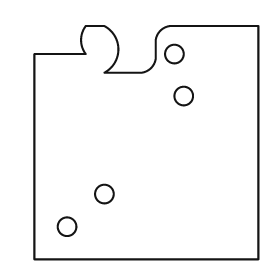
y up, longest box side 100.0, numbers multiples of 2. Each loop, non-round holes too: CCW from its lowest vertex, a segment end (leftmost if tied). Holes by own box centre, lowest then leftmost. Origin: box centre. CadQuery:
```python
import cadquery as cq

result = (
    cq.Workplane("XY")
    .moveTo(-48.0, -50.0)
    .lineTo(48.0, -50.0)
    .lineTo(48.0, 50.0)
    .lineTo(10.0, 50.0)
    .threePointArc((6.0, 48.0), (4.0, 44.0))
    .lineTo(4.0, 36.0)
    .threePointArc((2.0, 32.0), (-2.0, 30.0))
    .lineTo(-18.0, 30.0)
    .threePointArc((-12.0, 40.0), (-18.0, 50.0))
    .lineTo(-26.0, 50.0)
    .threePointArc((-28.0, 44.0), (-26.0, 38.0))
    .lineTo(-48.0, 38.0)
    .close()
    .moveTo(-34.0, -36.0)
    .circle(4.0)
    .moveTo(-18.0, -22.0)
    .circle(4.0)
    .moveTo(16.0, 20.0)
    .circle(4.0)
    .moveTo(12.0, 38.0)
    .circle(4.0)
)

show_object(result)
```